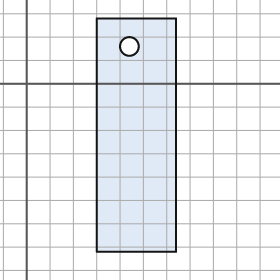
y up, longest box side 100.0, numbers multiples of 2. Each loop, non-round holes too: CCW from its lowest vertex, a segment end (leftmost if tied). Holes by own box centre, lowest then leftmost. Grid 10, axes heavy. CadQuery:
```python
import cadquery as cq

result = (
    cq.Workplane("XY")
    .moveTo(30.0, -72.0)
    .lineTo(64.0, -72.0)
    .lineTo(64.0, 28.0)
    .lineTo(30.0, 28.0)
    .close()
    .moveTo(44.0, 16.0)
    .circle(4.0)
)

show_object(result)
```